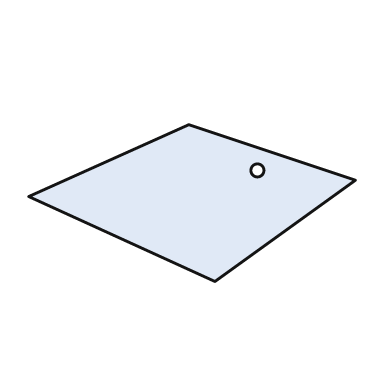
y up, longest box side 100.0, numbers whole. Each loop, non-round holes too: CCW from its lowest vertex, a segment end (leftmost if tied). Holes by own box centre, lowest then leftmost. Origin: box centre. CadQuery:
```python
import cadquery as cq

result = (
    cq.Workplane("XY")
    .moveTo(7.0, -24.0)
    .lineTo(50.0, 7.0)
    .lineTo(-1.0, 24.0)
    .lineTo(-50.0, 2.0)
    .close()
    .moveTo(20.0, 10.0)
    .circle(2.0)
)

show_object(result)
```